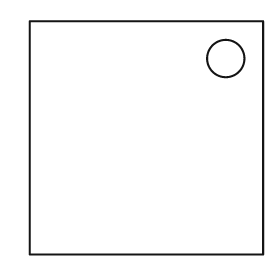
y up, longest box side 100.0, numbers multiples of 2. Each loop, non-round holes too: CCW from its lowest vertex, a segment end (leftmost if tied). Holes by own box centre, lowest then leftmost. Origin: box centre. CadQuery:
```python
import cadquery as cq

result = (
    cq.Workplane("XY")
    .moveTo(-50.0, -50.0)
    .lineTo(50.0, -50.0)
    .lineTo(50.0, 50.0)
    .lineTo(-50.0, 50.0)
    .close()
    .moveTo(34.0, 34.0)
    .circle(8.0)
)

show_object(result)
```